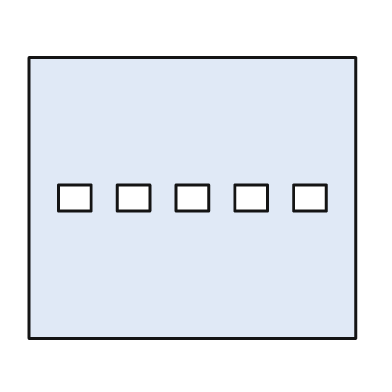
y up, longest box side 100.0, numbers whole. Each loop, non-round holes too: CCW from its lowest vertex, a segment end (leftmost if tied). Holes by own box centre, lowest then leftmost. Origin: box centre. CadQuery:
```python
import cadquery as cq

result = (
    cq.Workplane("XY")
    .moveTo(-50.0, -43.0)
    .lineTo(50.0, -43.0)
    .lineTo(50.0, 43.0)
    .lineTo(-50.0, 43.0)
    .close()
    .moveTo(-41.0, -4.0)
    .lineTo(-31.0, -4.0)
    .lineTo(-31.0, 4.0)
    .lineTo(-41.0, 4.0)
    .close()
    .moveTo(-23.0, -4.0)
    .lineTo(-13.0, -4.0)
    .lineTo(-13.0, 4.0)
    .lineTo(-23.0, 4.0)
    .close()
    .moveTo(-5.0, -4.0)
    .lineTo(5.0, -4.0)
    .lineTo(5.0, 4.0)
    .lineTo(-5.0, 4.0)
    .close()
    .moveTo(13.0, -4.0)
    .lineTo(23.0, -4.0)
    .lineTo(23.0, 4.0)
    .lineTo(13.0, 4.0)
    .close()
    .moveTo(31.0, -4.0)
    .lineTo(41.0, -4.0)
    .lineTo(41.0, 4.0)
    .lineTo(31.0, 4.0)
    .close()
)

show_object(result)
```